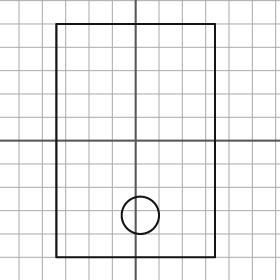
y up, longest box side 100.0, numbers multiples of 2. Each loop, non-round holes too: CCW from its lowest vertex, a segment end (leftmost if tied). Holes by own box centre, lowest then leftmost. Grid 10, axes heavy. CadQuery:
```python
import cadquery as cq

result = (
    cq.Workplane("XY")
    .moveTo(-34.0, -50.0)
    .lineTo(34.0, -50.0)
    .lineTo(34.0, 50.0)
    .lineTo(-34.0, 50.0)
    .close()
    .moveTo(2.0, -32.0)
    .circle(8.0)
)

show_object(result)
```